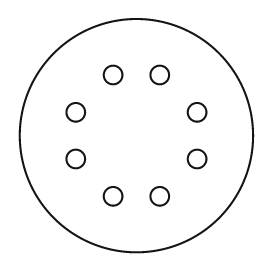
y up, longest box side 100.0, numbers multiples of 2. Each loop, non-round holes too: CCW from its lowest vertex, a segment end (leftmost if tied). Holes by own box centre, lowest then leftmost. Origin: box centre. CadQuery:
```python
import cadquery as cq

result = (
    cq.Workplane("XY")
    .moveTo(0.0, 0.0)
    .circle(50.0)
    .moveTo(-10.0, -26.0)
    .circle(4.0)
    .moveTo(10.0, -26.0)
    .circle(4.0)
    .moveTo(-26.0, -10.0)
    .circle(4.0)
    .moveTo(26.0, -10.0)
    .circle(4.0)
    .moveTo(-26.0, 10.0)
    .circle(4.0)
    .moveTo(26.0, 10.0)
    .circle(4.0)
    .moveTo(-10.0, 26.0)
    .circle(4.0)
    .moveTo(10.0, 26.0)
    .circle(4.0)
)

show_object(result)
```